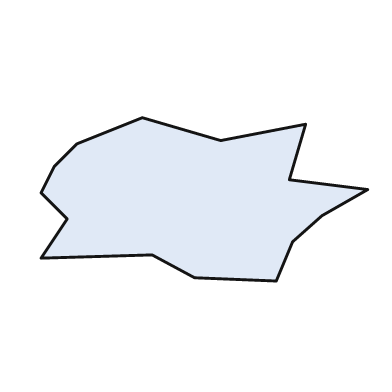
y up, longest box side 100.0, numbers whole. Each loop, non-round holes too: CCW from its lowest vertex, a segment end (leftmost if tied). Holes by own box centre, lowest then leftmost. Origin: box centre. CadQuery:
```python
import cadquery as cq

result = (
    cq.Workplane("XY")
    .moveTo(22.0, -25.0)
    .lineTo(27.0, -13.0)
    .lineTo(36.0, -5.0)
    .lineTo(50.0, 3.0)
    .lineTo(26.0, 6.0)
    .lineTo(31.0, 23.0)
    .lineTo(5.0, 18.0)
    .lineTo(-19.0, 25.0)
    .lineTo(-39.0, 17.0)
    .lineTo(-46.0, 10.0)
    .lineTo(-50.0, 2.0)
    .lineTo(-42.0, -6.0)
    .lineTo(-50.0, -18.0)
    .lineTo(-16.0, -17.0)
    .lineTo(-3.0, -24.0)
    .close()
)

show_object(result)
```